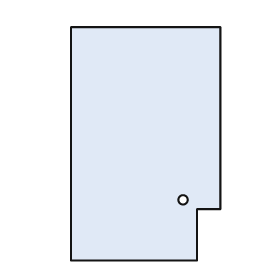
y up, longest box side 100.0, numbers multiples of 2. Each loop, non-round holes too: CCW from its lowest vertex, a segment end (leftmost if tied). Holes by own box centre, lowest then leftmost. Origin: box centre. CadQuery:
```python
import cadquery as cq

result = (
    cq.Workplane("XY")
    .moveTo(-32.0, -50.0)
    .lineTo(22.0, -50.0)
    .lineTo(22.0, -28.0)
    .lineTo(32.0, -28.0)
    .lineTo(32.0, 50.0)
    .lineTo(-32.0, 50.0)
    .close()
    .moveTo(16.0, -24.0)
    .circle(2.0)
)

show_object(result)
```